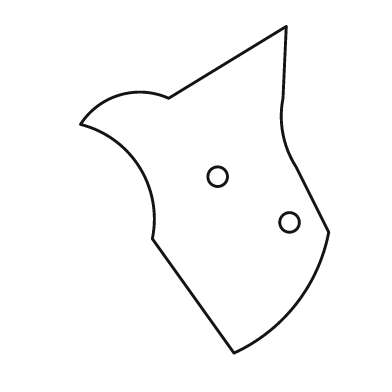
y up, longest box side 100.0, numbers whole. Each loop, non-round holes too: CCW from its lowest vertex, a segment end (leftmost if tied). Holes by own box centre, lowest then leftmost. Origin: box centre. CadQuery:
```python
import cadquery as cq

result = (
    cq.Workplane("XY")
    .moveTo(9.0, -50.0)
    .threePointArc((28.0, -35.0), (38.0, -13.0))
    .lineTo(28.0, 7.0)
    .threePointArc((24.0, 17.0), (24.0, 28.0))
    .lineTo(25.0, 50.0)
    .lineTo(-11.0, 28.0)
    .threePointArc((-26.0, 29.0), (-38.0, 20.0))
    .threePointArc((-20.0, 7.0), (-16.0, -15.0))
    .close()
    .moveTo(26.0, -10.0)
    .circle(3.0)
    .moveTo(4.0, 4.0)
    .circle(3.0)
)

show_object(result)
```